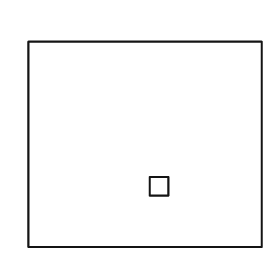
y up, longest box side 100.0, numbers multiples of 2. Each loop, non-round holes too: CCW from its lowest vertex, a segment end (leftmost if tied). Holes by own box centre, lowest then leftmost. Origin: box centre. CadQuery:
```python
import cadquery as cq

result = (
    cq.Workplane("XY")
    .moveTo(-50.0, -44.0)
    .lineTo(50.0, -44.0)
    .lineTo(50.0, 44.0)
    .lineTo(-50.0, 44.0)
    .close()
    .moveTo(2.0, -22.0)
    .lineTo(10.0, -22.0)
    .lineTo(10.0, -14.0)
    .lineTo(2.0, -14.0)
    .close()
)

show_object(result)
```